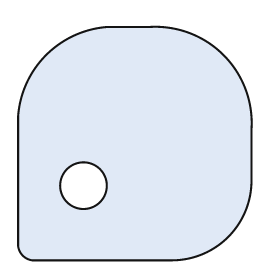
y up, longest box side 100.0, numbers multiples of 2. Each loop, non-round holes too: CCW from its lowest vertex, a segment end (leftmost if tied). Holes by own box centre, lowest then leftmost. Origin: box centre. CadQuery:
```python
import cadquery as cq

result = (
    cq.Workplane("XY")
    .moveTo(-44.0, -50.0)
    .lineTo(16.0, -50.0)
    .threePointArc((40.0, -40.0), (50.0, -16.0))
    .lineTo(50.0, 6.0)
    .threePointArc((38.0, 38.0), (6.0, 50.0))
    .lineTo(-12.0, 50.0)
    .threePointArc((-38.0, 38.0), (-50.0, 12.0))
    .lineTo(-50.0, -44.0)
    .threePointArc((-48.0, -48.0), (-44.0, -50.0))
    .close()
    .moveTo(-22.0, -18.0)
    .circle(10.0)
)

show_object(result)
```